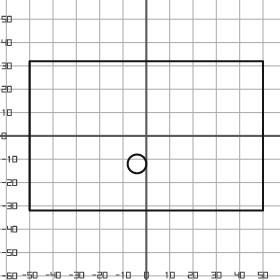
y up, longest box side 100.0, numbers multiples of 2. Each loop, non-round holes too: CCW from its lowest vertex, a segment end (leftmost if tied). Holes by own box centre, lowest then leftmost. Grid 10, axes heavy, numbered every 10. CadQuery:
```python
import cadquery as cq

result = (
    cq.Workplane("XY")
    .moveTo(-50.0, -32.0)
    .lineTo(50.0, -32.0)
    .lineTo(50.0, 32.0)
    .lineTo(-50.0, 32.0)
    .close()
    .moveTo(-4.0, -12.0)
    .circle(4.0)
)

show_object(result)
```